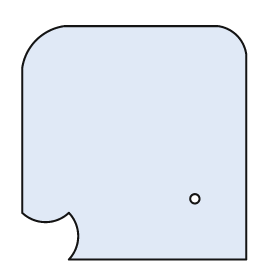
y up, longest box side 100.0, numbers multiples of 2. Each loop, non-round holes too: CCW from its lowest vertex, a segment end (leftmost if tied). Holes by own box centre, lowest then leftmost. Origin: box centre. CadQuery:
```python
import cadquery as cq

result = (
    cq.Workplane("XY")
    .moveTo(-28.0, -50.0)
    .lineTo(48.0, -50.0)
    .lineTo(48.0, 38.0)
    .threePointArc((44.0, 46.0), (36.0, 50.0))
    .lineTo(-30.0, 50.0)
    .threePointArc((-42.0, 44.0), (-48.0, 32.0))
    .lineTo(-48.0, -30.0)
    .threePointArc((-38.0, -34.0), (-28.0, -30.0))
    .threePointArc((-24.0, -40.0), (-28.0, -50.0))
    .close()
    .moveTo(26.0, -24.0)
    .circle(2.0)
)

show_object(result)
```